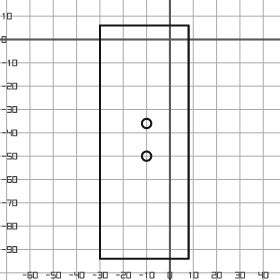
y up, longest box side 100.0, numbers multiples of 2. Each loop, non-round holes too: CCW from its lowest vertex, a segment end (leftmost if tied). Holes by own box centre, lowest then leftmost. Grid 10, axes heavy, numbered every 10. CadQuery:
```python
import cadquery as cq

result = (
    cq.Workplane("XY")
    .moveTo(-30.0, -94.0)
    .lineTo(8.0, -94.0)
    .lineTo(8.0, 6.0)
    .lineTo(-30.0, 6.0)
    .close()
    .moveTo(-10.0, -50.0)
    .circle(2.0)
    .moveTo(-10.0, -36.0)
    .circle(2.0)
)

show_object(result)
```